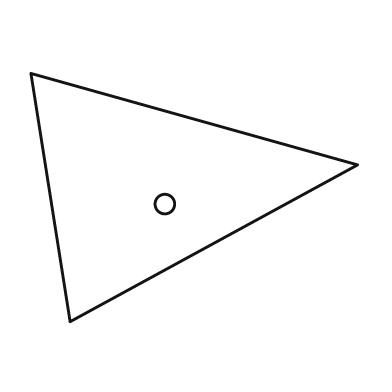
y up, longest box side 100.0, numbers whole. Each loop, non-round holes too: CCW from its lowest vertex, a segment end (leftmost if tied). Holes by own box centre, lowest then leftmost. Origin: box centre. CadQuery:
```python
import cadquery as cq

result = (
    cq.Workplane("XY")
    .moveTo(-38.0, -38.0)
    .lineTo(50.0, 10.0)
    .lineTo(-50.0, 38.0)
    .close()
    .moveTo(-9.0, -2.0)
    .circle(3.0)
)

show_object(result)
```